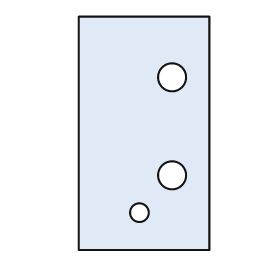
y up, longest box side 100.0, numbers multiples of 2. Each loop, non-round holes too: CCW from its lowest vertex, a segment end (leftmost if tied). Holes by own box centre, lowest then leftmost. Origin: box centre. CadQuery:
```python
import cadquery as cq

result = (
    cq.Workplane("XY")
    .moveTo(-28.0, -50.0)
    .lineTo(28.0, -50.0)
    .lineTo(28.0, 50.0)
    .lineTo(-28.0, 50.0)
    .close()
    .moveTo(-2.0, -34.0)
    .circle(4.0)
    .moveTo(12.0, -18.0)
    .circle(6.0)
    .moveTo(12.0, 24.0)
    .circle(6.0)
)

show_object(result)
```